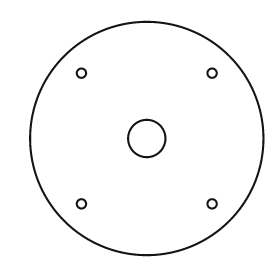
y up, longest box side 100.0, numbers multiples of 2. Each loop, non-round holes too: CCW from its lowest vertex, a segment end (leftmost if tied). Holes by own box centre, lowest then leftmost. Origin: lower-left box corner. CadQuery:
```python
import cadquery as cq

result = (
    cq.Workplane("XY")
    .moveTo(50.0, 50.0)
    .circle(50.0)
    .moveTo(22.0, 22.0)
    .circle(2.0)
    .moveTo(78.0, 22.0)
    .circle(2.0)
    .moveTo(50.0, 50.0)
    .circle(8.0)
    .moveTo(22.0, 78.0)
    .circle(2.0)
    .moveTo(78.0, 78.0)
    .circle(2.0)
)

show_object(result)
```